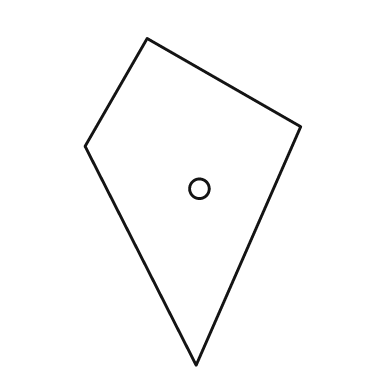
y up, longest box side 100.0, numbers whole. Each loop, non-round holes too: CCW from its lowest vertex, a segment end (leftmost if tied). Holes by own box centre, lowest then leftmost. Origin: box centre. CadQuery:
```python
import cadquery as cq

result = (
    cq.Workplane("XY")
    .moveTo(1.0, -50.0)
    .lineTo(33.0, 23.0)
    .lineTo(-14.0, 50.0)
    .lineTo(-33.0, 17.0)
    .close()
    .moveTo(2.0, 4.0)
    .circle(3.0)
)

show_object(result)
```